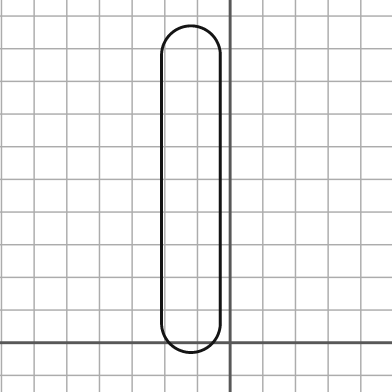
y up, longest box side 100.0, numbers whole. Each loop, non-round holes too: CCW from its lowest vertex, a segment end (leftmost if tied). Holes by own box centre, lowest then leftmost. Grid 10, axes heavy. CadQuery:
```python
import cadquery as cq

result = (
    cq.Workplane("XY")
    .moveTo(-21.0, 6.0)
    .threePointArc((-12.0, -3.0), (-3.0, 6.0))
    .lineTo(-3.0, 88.0)
    .threePointArc((-12.0, 97.0), (-21.0, 88.0))
    .close()
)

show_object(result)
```